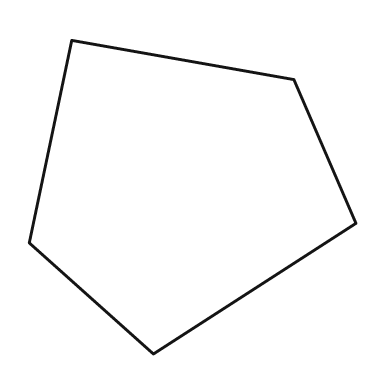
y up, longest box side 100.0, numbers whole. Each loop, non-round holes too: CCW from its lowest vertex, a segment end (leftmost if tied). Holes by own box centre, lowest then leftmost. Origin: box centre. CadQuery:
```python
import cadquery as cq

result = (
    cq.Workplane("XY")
    .moveTo(-12.0, -48.0)
    .lineTo(50.0, -8.0)
    .lineTo(31.0, 36.0)
    .lineTo(-37.0, 48.0)
    .lineTo(-50.0, -14.0)
    .close()
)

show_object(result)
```